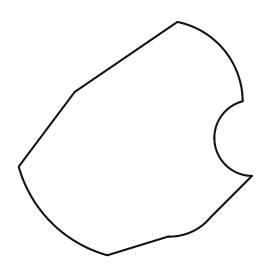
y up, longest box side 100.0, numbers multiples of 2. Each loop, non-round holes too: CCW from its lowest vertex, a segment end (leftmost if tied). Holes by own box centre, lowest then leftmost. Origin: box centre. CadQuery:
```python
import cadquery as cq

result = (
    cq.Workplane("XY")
    .moveTo(-12.0, -50.0)
    .lineTo(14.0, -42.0)
    .threePointArc((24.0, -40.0), (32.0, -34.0))
    .lineTo(50.0, -16.0)
    .threePointArc((34.0, -2.0), (46.0, 16.0))
    .threePointArc((38.0, 38.0), (18.0, 50.0))
    .lineTo(-26.0, 20.0)
    .lineTo(-50.0, -12.0)
    .threePointArc((-36.0, -36.0), (-12.0, -50.0))
    .close()
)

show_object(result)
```